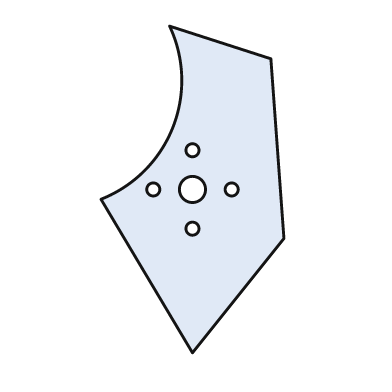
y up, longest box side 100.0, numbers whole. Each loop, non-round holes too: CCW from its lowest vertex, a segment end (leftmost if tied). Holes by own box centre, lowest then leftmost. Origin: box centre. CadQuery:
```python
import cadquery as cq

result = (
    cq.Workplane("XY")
    .moveTo(0.0, -50.0)
    .lineTo(28.0, -15.0)
    .lineTo(24.0, 40.0)
    .lineTo(-7.0, 50.0)
    .threePointArc((-6.0, 19.0), (-28.0, -3.0))
    .close()
    .moveTo(0.0, -12.0)
    .circle(2.0)
    .moveTo(-12.0, 0.0)
    .circle(2.0)
    .moveTo(0.0, 0.0)
    .circle(4.0)
    .moveTo(12.0, 0.0)
    .circle(2.0)
    .moveTo(0.0, 12.0)
    .circle(2.0)
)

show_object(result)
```